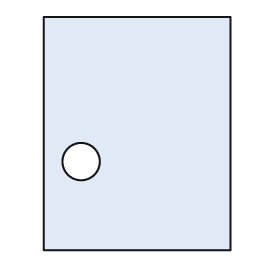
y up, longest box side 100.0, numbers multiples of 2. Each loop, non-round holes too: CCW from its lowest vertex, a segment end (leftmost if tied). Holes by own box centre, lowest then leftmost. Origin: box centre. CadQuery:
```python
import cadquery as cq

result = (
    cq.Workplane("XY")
    .moveTo(-40.0, -50.0)
    .lineTo(40.0, -50.0)
    .lineTo(40.0, 50.0)
    .lineTo(-40.0, 50.0)
    .close()
    .moveTo(-24.0, -12.0)
    .circle(8.0)
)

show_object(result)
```